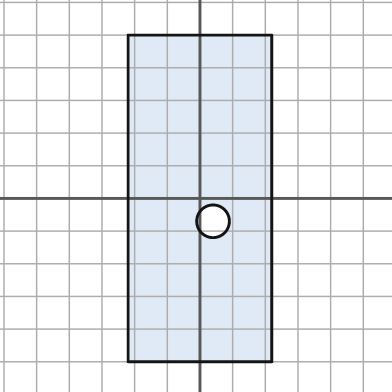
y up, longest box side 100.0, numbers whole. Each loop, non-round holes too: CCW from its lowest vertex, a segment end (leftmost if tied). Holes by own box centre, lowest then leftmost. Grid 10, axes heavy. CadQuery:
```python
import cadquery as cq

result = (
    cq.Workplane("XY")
    .moveTo(-22.0, -50.0)
    .lineTo(22.0, -50.0)
    .lineTo(22.0, 50.0)
    .lineTo(-22.0, 50.0)
    .close()
    .moveTo(4.0, -7.0)
    .circle(5.0)
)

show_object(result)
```